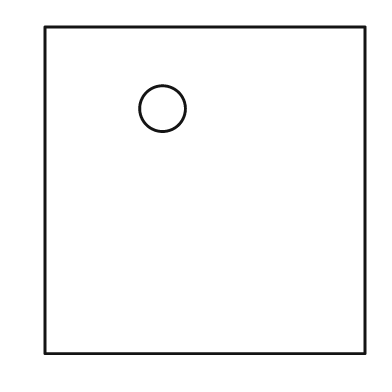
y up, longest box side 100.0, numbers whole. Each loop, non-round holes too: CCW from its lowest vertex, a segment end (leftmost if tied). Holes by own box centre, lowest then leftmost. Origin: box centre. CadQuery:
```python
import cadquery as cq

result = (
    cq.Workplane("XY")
    .moveTo(-49.0, -50.0)
    .lineTo(49.0, -50.0)
    .lineTo(49.0, 50.0)
    .lineTo(-49.0, 50.0)
    .close()
    .moveTo(-13.0, 25.0)
    .circle(7.0)
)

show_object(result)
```